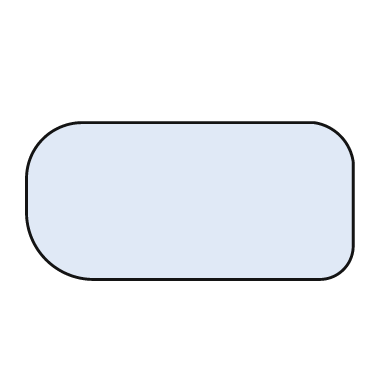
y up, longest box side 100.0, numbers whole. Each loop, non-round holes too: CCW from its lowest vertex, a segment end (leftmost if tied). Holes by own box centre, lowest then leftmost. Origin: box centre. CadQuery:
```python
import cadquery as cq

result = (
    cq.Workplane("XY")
    .moveTo(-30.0, -24.0)
    .lineTo(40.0, -24.0)
    .threePointArc((47.0, -21.0), (50.0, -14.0))
    .lineTo(50.0, 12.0)
    .threePointArc((46.0, 20.0), (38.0, 24.0))
    .lineTo(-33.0, 24.0)
    .threePointArc((-45.0, 19.0), (-50.0, 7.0))
    .lineTo(-50.0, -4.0)
    .threePointArc((-44.0, -18.0), (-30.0, -24.0))
    .close()
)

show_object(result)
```